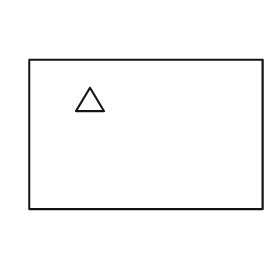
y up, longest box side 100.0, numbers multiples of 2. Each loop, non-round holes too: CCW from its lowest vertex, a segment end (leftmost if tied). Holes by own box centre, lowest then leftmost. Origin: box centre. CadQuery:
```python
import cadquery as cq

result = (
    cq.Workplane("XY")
    .moveTo(-50.0, -32.0)
    .lineTo(50.0, -32.0)
    .lineTo(50.0, 32.0)
    .lineTo(-50.0, 32.0)
    .close()
    .moveTo(-30.0, 10.0)
    .lineTo(-18.0, 10.0)
    .lineTo(-24.0, 20.0)
    .close()
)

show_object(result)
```